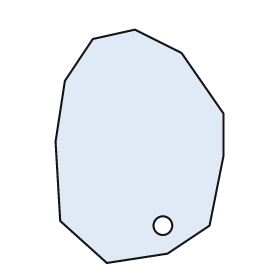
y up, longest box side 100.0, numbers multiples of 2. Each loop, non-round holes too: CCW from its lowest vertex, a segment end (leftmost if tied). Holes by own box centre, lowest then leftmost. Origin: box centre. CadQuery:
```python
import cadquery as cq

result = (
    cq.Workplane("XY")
    .moveTo(-14.0, -50.0)
    .lineTo(12.0, -46.0)
    .lineTo(30.0, -34.0)
    .lineTo(36.0, -4.0)
    .lineTo(36.0, 14.0)
    .lineTo(18.0, 40.0)
    .lineTo(-2.0, 50.0)
    .lineTo(-20.0, 46.0)
    .lineTo(-32.0, 28.0)
    .lineTo(-36.0, 2.0)
    .lineTo(-34.0, -32.0)
    .close()
    .moveTo(10.0, -34.0)
    .circle(4.0)
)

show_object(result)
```